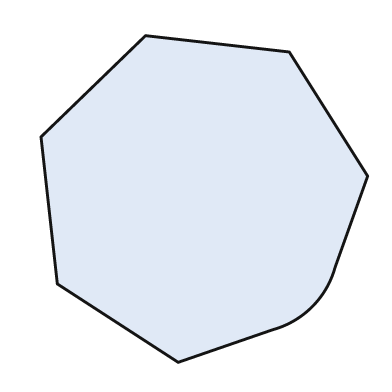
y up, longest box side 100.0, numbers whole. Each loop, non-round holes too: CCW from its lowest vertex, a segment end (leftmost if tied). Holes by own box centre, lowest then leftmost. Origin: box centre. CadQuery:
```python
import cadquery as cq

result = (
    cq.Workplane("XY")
    .moveTo(-8.0, -50.0)
    .lineTo(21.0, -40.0)
    .threePointArc((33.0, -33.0), (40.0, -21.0))
    .lineTo(50.0, 7.0)
    .lineTo(26.0, 45.0)
    .lineTo(-18.0, 50.0)
    .lineTo(-50.0, 19.0)
    .lineTo(-45.0, -26.0)
    .close()
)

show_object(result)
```